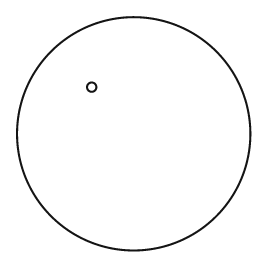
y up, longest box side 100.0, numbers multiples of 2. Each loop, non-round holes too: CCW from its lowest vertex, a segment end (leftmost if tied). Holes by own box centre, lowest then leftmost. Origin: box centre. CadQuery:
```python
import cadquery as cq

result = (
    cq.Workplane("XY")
    .moveTo(0.0, 0.0)
    .circle(50.0)
    .moveTo(-18.0, 20.0)
    .circle(2.0)
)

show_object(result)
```